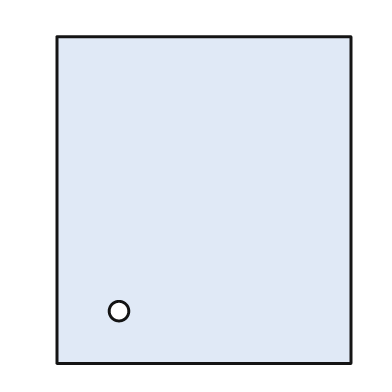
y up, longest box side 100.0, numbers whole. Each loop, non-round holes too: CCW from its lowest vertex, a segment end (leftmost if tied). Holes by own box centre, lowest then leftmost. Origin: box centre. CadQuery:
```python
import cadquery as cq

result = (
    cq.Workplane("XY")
    .moveTo(-45.0, -50.0)
    .lineTo(45.0, -50.0)
    .lineTo(45.0, 50.0)
    .lineTo(-45.0, 50.0)
    .close()
    .moveTo(-26.0, -34.0)
    .circle(3.0)
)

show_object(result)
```